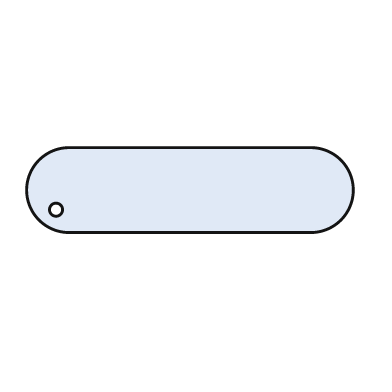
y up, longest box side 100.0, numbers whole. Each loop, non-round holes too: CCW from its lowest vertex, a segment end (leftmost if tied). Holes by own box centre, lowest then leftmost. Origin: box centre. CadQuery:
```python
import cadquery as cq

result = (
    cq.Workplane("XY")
    .moveTo(-37.0, -13.0)
    .lineTo(37.0, -13.0)
    .threePointArc((50.0, 0.0), (37.0, 13.0))
    .lineTo(-37.0, 13.0)
    .threePointArc((-50.0, 0.0), (-37.0, -13.0))
    .close()
    .moveTo(-41.0, -6.0)
    .circle(2.0)
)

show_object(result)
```